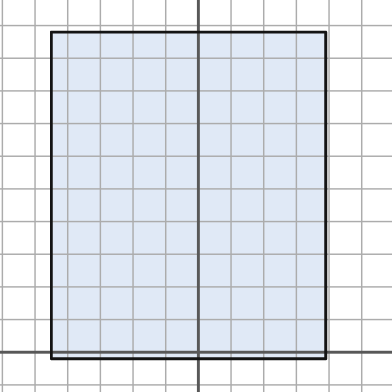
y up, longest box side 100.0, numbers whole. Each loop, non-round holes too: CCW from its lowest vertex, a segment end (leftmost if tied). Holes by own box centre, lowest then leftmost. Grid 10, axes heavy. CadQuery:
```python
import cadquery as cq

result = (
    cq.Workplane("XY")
    .moveTo(-45.0, -2.0)
    .lineTo(39.0, -2.0)
    .lineTo(39.0, 98.0)
    .lineTo(-45.0, 98.0)
    .close()
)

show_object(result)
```